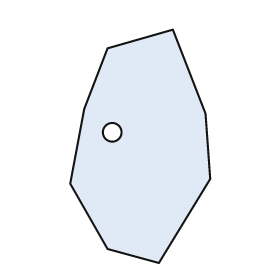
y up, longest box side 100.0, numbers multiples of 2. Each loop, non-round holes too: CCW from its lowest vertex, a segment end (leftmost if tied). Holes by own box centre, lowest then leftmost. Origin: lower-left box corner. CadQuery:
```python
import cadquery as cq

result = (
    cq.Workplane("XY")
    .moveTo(38.0, 0.0)
    .lineTo(60.0, 36.0)
    .lineTo(58.0, 64.0)
    .lineTo(44.0, 100.0)
    .lineTo(16.0, 92.0)
    .lineTo(6.0, 66.0)
    .lineTo(0.0, 34.0)
    .lineTo(16.0, 6.0)
    .close()
    .moveTo(18.0, 56.0)
    .circle(4.0)
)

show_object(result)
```